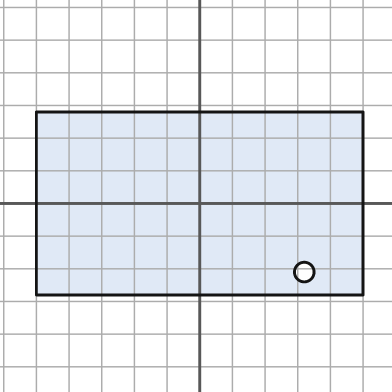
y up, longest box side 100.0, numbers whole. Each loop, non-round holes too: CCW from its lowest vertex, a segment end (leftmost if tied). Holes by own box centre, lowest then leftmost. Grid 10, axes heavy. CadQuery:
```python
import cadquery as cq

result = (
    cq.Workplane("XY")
    .moveTo(-50.0, -28.0)
    .lineTo(50.0, -28.0)
    .lineTo(50.0, 28.0)
    .lineTo(-50.0, 28.0)
    .close()
    .moveTo(32.0, -21.0)
    .circle(3.0)
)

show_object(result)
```